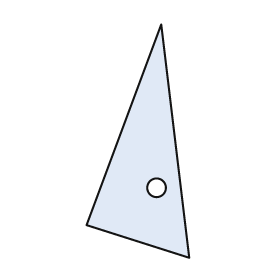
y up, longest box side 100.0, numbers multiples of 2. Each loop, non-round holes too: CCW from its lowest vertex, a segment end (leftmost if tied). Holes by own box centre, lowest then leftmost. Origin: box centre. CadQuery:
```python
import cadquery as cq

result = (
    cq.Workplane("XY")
    .moveTo(22.0, -50.0)
    .lineTo(10.0, 50.0)
    .lineTo(-22.0, -36.0)
    .close()
    .moveTo(8.0, -20.0)
    .circle(4.0)
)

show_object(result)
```